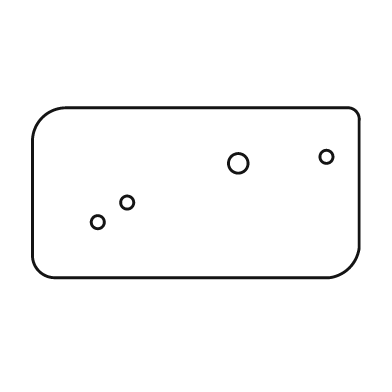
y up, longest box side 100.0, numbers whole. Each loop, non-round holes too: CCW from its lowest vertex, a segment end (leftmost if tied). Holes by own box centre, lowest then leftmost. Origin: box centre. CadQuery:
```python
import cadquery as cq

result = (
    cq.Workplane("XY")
    .moveTo(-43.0, -26.0)
    .lineTo(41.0, -26.0)
    .threePointArc((47.0, -23.0), (50.0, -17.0))
    .lineTo(50.0, 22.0)
    .threePointArc((49.0, 25.0), (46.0, 26.0))
    .lineTo(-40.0, 26.0)
    .threePointArc((-47.0, 23.0), (-50.0, 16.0))
    .lineTo(-50.0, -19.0)
    .threePointArc((-48.0, -24.0), (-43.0, -26.0))
    .close()
    .moveTo(-30.0, -9.0)
    .circle(2.0)
    .moveTo(-21.0, -3.0)
    .circle(2.0)
    .moveTo(13.0, 9.0)
    .circle(3.0)
    .moveTo(40.0, 11.0)
    .circle(2.0)
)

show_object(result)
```